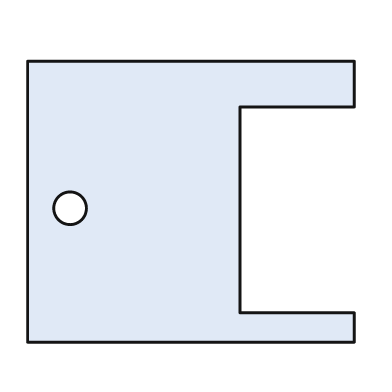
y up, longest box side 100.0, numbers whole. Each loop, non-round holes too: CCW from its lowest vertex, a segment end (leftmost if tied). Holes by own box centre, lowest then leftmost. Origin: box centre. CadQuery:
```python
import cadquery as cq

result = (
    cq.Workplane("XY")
    .moveTo(-50.0, -43.0)
    .lineTo(50.0, -43.0)
    .lineTo(50.0, -34.0)
    .lineTo(15.0, -34.0)
    .lineTo(15.0, 29.0)
    .lineTo(50.0, 29.0)
    .lineTo(50.0, 43.0)
    .lineTo(-50.0, 43.0)
    .close()
    .moveTo(-37.0, -2.0)
    .circle(5.0)
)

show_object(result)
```